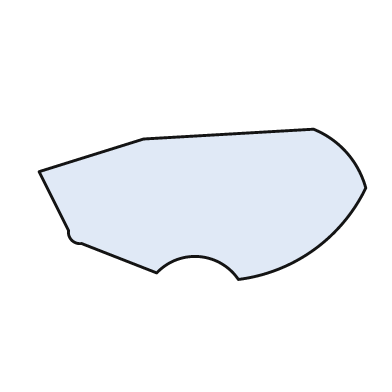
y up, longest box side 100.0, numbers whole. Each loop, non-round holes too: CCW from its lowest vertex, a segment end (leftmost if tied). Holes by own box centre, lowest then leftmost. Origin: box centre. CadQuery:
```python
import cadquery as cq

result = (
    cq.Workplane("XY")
    .moveTo(11.0, -23.0)
    .threePointArc((34.0, -14.0), (50.0, 5.0))
    .threePointArc((44.0, 16.0), (34.0, 23.0))
    .lineTo(-18.0, 20.0)
    .lineTo(-50.0, 10.0)
    .lineTo(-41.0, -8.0)
    .threePointArc((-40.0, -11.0), (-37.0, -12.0))
    .lineTo(-14.0, -21.0)
    .threePointArc((-1.0, -16.0), (11.0, -23.0))
    .close()
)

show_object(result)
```